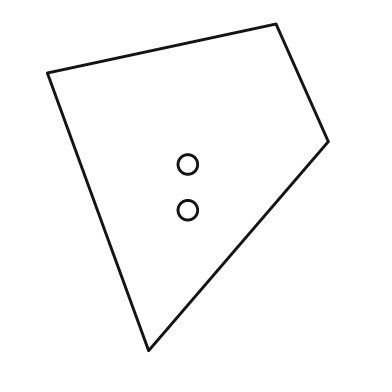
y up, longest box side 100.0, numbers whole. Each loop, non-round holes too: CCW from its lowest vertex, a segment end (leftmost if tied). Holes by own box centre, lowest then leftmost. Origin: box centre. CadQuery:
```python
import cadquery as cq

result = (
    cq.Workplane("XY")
    .moveTo(-12.0, -50.0)
    .lineTo(43.0, 14.0)
    .lineTo(27.0, 50.0)
    .lineTo(-43.0, 35.0)
    .close()
    .moveTo(0.0, -7.0)
    .circle(3.0)
    .moveTo(0.0, 7.0)
    .circle(3.0)
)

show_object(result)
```